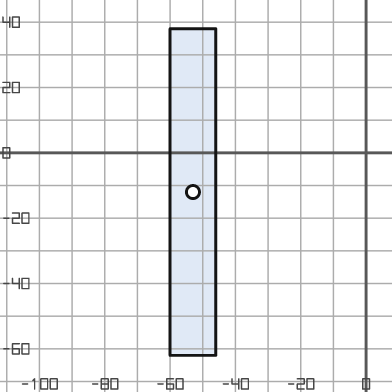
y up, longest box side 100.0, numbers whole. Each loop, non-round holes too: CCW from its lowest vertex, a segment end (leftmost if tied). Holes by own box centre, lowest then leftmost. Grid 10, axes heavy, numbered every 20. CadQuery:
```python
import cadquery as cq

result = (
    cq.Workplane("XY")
    .moveTo(-60.0, -62.0)
    .lineTo(-46.0, -62.0)
    .lineTo(-46.0, 38.0)
    .lineTo(-60.0, 38.0)
    .close()
    .moveTo(-53.0, -12.0)
    .circle(2.0)
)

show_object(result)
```